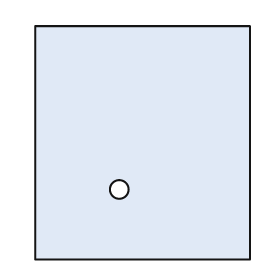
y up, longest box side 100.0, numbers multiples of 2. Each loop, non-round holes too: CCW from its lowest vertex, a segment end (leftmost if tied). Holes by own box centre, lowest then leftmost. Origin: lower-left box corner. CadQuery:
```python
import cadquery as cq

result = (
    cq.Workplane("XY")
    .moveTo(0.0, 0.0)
    .lineTo(92.0, 0.0)
    .lineTo(92.0, 100.0)
    .lineTo(0.0, 100.0)
    .close()
    .moveTo(36.0, 30.0)
    .circle(4.0)
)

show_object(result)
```